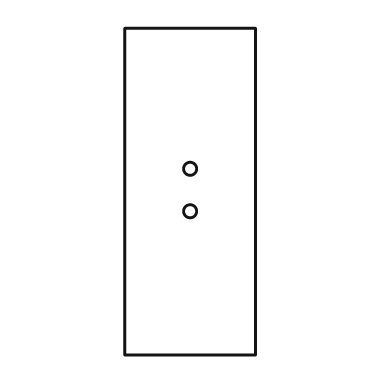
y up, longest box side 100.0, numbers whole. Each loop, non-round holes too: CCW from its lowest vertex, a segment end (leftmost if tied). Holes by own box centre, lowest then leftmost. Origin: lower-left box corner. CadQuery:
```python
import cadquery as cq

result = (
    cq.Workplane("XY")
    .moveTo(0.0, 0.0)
    .lineTo(40.0, 0.0)
    .lineTo(40.0, 100.0)
    .lineTo(0.0, 100.0)
    .close()
    .moveTo(20.0, 44.0)
    .circle(2.0)
    .moveTo(20.0, 57.0)
    .circle(2.0)
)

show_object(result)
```